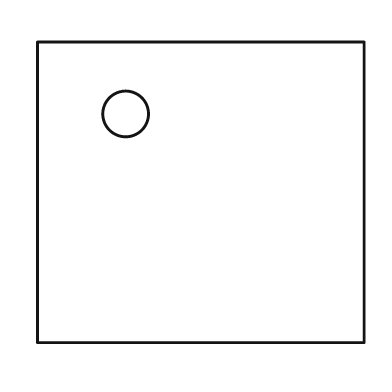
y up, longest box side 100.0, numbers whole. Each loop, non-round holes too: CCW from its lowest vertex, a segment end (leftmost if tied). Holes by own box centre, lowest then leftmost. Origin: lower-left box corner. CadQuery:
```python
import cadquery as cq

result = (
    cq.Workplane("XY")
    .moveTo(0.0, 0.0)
    .lineTo(100.0, 0.0)
    .lineTo(100.0, 92.0)
    .lineTo(0.0, 92.0)
    .close()
    .moveTo(27.0, 70.0)
    .circle(7.0)
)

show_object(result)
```